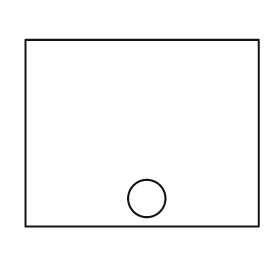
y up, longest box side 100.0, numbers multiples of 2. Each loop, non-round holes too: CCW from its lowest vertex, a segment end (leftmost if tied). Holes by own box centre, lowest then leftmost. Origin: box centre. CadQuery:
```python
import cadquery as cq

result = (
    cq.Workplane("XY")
    .moveTo(-50.0, -40.0)
    .lineTo(50.0, -40.0)
    .lineTo(50.0, 40.0)
    .lineTo(-50.0, 40.0)
    .close()
    .moveTo(2.0, -28.0)
    .circle(8.0)
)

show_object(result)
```